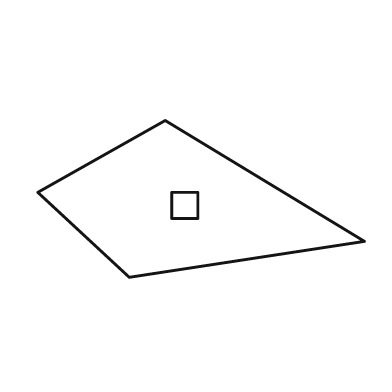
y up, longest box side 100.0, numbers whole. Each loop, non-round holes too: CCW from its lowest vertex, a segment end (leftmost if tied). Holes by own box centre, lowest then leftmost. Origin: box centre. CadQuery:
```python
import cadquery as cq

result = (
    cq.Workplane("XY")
    .moveTo(-22.0, -24.0)
    .lineTo(50.0, -13.0)
    .lineTo(-11.0, 24.0)
    .lineTo(-50.0, 2.0)
    .close()
    .moveTo(-9.0, -6.0)
    .lineTo(-1.0, -6.0)
    .lineTo(-1.0, 2.0)
    .lineTo(-9.0, 2.0)
    .close()
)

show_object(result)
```